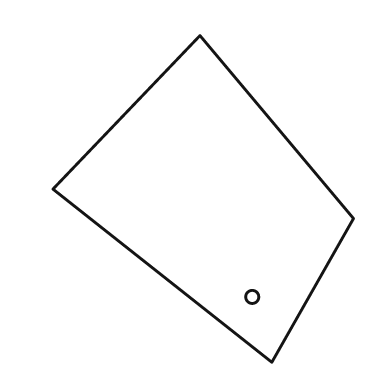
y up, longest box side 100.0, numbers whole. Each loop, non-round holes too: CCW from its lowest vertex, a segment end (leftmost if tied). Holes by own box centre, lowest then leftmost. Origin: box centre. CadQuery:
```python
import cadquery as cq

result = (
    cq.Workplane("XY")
    .moveTo(21.0, -50.0)
    .lineTo(46.0, -6.0)
    .lineTo(-1.0, 50.0)
    .lineTo(-46.0, 3.0)
    .close()
    .moveTo(15.0, -30.0)
    .circle(2.0)
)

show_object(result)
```